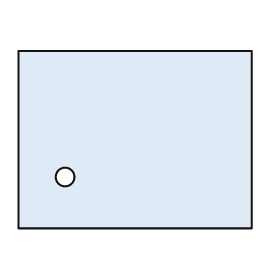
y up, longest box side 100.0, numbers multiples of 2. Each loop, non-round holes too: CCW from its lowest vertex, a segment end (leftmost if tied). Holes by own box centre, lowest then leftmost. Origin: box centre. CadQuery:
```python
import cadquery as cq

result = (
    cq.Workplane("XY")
    .moveTo(-50.0, -38.0)
    .lineTo(50.0, -38.0)
    .lineTo(50.0, 38.0)
    .lineTo(-50.0, 38.0)
    .close()
    .moveTo(-30.0, -16.0)
    .circle(4.0)
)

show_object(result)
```